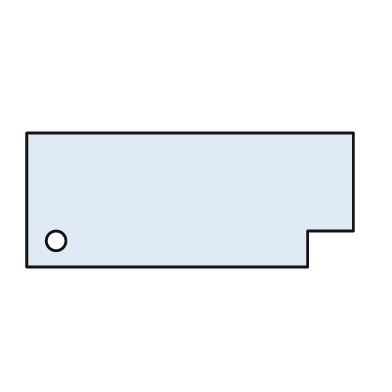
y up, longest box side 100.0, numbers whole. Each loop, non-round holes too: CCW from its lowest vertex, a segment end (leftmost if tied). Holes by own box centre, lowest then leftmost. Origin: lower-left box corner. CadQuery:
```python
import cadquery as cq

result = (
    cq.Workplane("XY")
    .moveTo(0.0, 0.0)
    .lineTo(86.0, 0.0)
    .lineTo(86.0, 11.0)
    .lineTo(100.0, 11.0)
    .lineTo(100.0, 41.0)
    .lineTo(0.0, 41.0)
    .close()
    .moveTo(9.0, 8.0)
    .circle(3.0)
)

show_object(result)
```